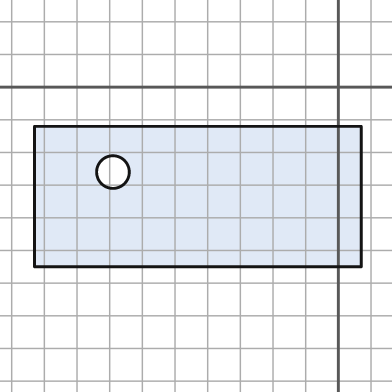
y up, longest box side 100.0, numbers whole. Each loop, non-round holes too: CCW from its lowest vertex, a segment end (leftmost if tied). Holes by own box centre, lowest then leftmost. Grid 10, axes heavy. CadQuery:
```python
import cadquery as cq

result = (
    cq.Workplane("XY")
    .moveTo(-93.0, -55.0)
    .lineTo(7.0, -55.0)
    .lineTo(7.0, -12.0)
    .lineTo(-93.0, -12.0)
    .close()
    .moveTo(-69.0, -26.0)
    .circle(5.0)
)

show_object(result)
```